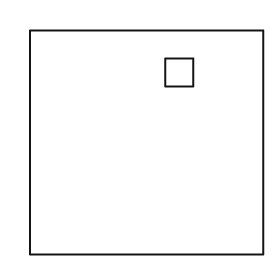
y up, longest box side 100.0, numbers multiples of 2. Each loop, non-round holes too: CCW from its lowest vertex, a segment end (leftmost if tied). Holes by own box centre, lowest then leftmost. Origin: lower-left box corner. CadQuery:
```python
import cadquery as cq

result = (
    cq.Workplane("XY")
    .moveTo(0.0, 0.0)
    .lineTo(100.0, 0.0)
    .lineTo(100.0, 96.0)
    .lineTo(0.0, 96.0)
    .close()
    .moveTo(58.0, 72.0)
    .lineTo(70.0, 72.0)
    .lineTo(70.0, 84.0)
    .lineTo(58.0, 84.0)
    .close()
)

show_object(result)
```